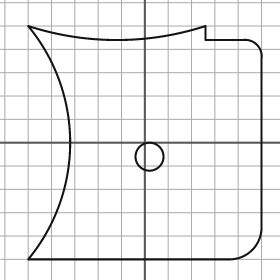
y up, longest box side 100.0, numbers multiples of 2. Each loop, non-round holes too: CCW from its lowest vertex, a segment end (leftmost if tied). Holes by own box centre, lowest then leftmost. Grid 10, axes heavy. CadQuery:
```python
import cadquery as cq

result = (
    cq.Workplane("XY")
    .moveTo(-50.0, -50.0)
    .lineTo(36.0, -50.0)
    .threePointArc((46.0, -46.0), (50.0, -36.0))
    .lineTo(50.0, 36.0)
    .threePointArc((48.0, 42.0), (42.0, 44.0))
    .lineTo(26.0, 44.0)
    .lineTo(26.0, 50.0)
    .threePointArc((-12.0, 44.0), (-50.0, 50.0))
    .threePointArc((-32.0, 0.0), (-50.0, -50.0))
    .close()
    .moveTo(2.0, -6.0)
    .circle(6.0)
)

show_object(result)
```